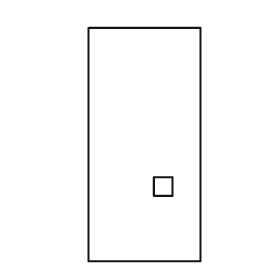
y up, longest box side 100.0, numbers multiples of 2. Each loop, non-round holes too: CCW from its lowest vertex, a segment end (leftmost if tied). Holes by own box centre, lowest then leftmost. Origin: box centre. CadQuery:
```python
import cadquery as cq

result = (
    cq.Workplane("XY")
    .moveTo(-24.0, -50.0)
    .lineTo(24.0, -50.0)
    .lineTo(24.0, 50.0)
    .lineTo(-24.0, 50.0)
    .close()
    .moveTo(4.0, -22.0)
    .lineTo(12.0, -22.0)
    .lineTo(12.0, -14.0)
    .lineTo(4.0, -14.0)
    .close()
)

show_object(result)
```